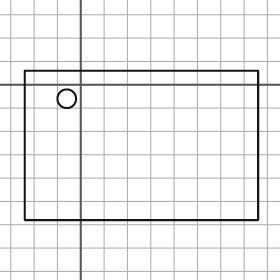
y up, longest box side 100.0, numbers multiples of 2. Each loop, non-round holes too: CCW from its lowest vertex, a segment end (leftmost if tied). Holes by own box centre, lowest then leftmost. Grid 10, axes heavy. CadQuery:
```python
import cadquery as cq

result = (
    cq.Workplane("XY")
    .moveTo(-24.0, -58.0)
    .lineTo(76.0, -58.0)
    .lineTo(76.0, 6.0)
    .lineTo(-24.0, 6.0)
    .close()
    .moveTo(-6.0, -6.0)
    .circle(4.0)
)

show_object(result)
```